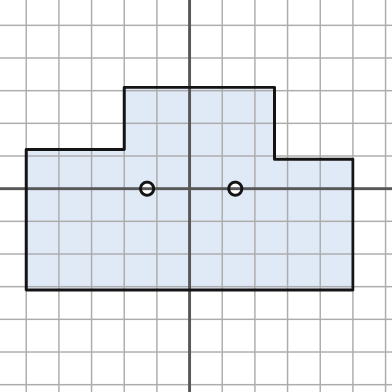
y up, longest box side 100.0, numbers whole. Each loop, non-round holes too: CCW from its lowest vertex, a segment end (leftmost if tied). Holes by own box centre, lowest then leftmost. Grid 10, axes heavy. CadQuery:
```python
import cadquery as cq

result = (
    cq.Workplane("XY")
    .moveTo(-50.0, -31.0)
    .lineTo(50.0, -31.0)
    .lineTo(50.0, 9.0)
    .lineTo(26.0, 9.0)
    .lineTo(26.0, 31.0)
    .lineTo(-20.0, 31.0)
    .lineTo(-20.0, 12.0)
    .lineTo(-50.0, 12.0)
    .close()
    .moveTo(-13.0, 0.0)
    .circle(2.0)
    .moveTo(14.0, 0.0)
    .circle(2.0)
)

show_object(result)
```